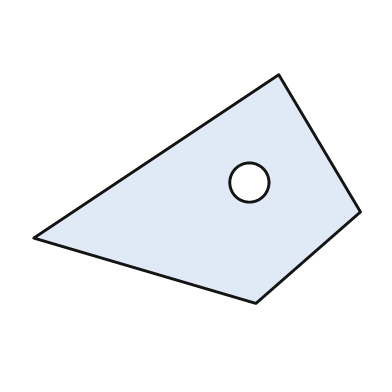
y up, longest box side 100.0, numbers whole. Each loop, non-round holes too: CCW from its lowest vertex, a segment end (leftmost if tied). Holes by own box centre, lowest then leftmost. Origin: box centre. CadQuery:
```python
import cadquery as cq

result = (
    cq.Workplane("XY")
    .moveTo(18.0, -35.0)
    .lineTo(50.0, -7.0)
    .lineTo(25.0, 35.0)
    .lineTo(-50.0, -15.0)
    .close()
    .moveTo(16.0, 2.0)
    .circle(6.0)
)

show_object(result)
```